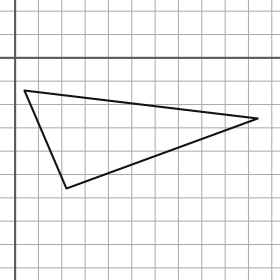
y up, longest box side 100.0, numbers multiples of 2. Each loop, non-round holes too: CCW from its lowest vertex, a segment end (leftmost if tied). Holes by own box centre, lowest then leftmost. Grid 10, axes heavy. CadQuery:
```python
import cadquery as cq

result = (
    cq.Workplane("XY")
    .moveTo(22.0, -56.0)
    .lineTo(104.0, -26.0)
    .lineTo(4.0, -14.0)
    .close()
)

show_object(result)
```